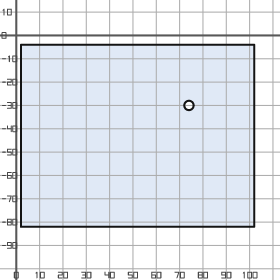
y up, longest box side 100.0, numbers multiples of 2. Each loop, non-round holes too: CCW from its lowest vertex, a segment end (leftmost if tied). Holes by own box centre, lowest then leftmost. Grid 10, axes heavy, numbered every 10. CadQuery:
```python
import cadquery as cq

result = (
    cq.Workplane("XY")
    .moveTo(2.0, -82.0)
    .lineTo(102.0, -82.0)
    .lineTo(102.0, -4.0)
    .lineTo(2.0, -4.0)
    .close()
    .moveTo(74.0, -30.0)
    .circle(2.0)
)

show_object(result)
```